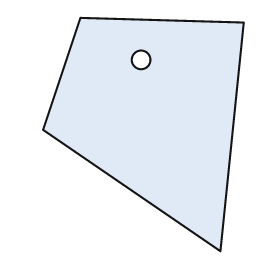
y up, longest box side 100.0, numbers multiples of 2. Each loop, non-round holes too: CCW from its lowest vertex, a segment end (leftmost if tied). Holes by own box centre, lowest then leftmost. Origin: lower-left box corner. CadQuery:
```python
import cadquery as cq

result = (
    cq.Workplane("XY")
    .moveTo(76.0, 0.0)
    .lineTo(86.0, 98.0)
    .lineTo(16.0, 100.0)
    .lineTo(0.0, 52.0)
    .close()
    .moveTo(42.0, 82.0)
    .circle(4.0)
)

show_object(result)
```